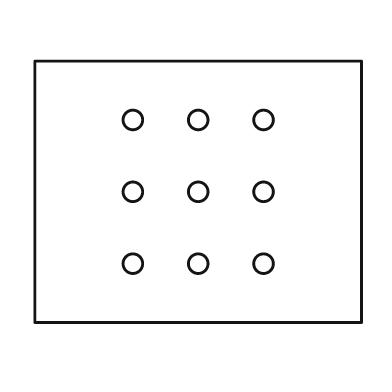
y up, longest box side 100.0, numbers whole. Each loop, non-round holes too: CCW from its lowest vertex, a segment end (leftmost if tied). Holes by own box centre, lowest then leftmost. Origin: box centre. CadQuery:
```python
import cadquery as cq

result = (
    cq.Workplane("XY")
    .moveTo(-50.0, -40.0)
    .lineTo(50.0, -40.0)
    .lineTo(50.0, 40.0)
    .lineTo(-50.0, 40.0)
    .close()
    .moveTo(-20.0, -22.0)
    .circle(3.0)
    .moveTo(0.0, -22.0)
    .circle(3.0)
    .moveTo(20.0, -22.0)
    .circle(3.0)
    .moveTo(-20.0, 0.0)
    .circle(3.0)
    .moveTo(0.0, 0.0)
    .circle(3.0)
    .moveTo(20.0, 0.0)
    .circle(3.0)
    .moveTo(-20.0, 22.0)
    .circle(3.0)
    .moveTo(0.0, 22.0)
    .circle(3.0)
    .moveTo(20.0, 22.0)
    .circle(3.0)
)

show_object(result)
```